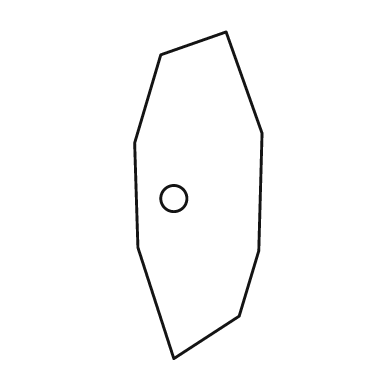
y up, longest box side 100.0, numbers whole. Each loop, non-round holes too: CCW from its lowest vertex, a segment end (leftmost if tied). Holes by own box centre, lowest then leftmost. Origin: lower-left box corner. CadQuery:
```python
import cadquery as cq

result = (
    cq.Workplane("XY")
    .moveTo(12.0, 0.0)
    .lineTo(32.0, 13.0)
    .lineTo(38.0, 33.0)
    .lineTo(39.0, 69.0)
    .lineTo(28.0, 100.0)
    .lineTo(8.0, 93.0)
    .lineTo(0.0, 66.0)
    .lineTo(1.0, 34.0)
    .close()
    .moveTo(12.0, 49.0)
    .circle(4.0)
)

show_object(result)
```